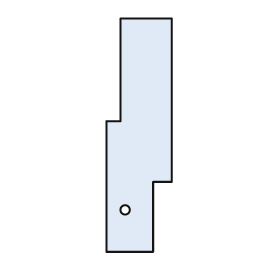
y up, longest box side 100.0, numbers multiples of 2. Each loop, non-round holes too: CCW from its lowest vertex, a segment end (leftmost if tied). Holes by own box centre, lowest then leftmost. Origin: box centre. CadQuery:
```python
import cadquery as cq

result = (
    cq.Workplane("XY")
    .moveTo(-14.0, -50.0)
    .lineTo(6.0, -50.0)
    .lineTo(6.0, -20.0)
    .lineTo(14.0, -20.0)
    .lineTo(14.0, 50.0)
    .lineTo(-8.0, 50.0)
    .lineTo(-8.0, 6.0)
    .lineTo(-14.0, 6.0)
    .close()
    .moveTo(-6.0, -32.0)
    .circle(2.0)
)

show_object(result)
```